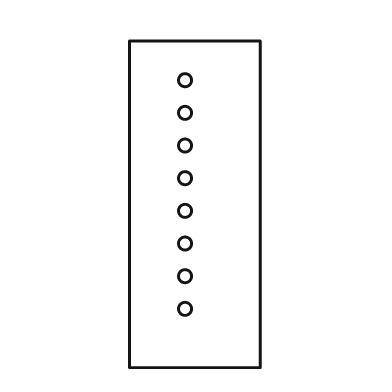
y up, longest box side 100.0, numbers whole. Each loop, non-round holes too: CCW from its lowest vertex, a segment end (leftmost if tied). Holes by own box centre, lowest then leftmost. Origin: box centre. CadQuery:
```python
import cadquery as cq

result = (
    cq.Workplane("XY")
    .moveTo(-20.0, -50.0)
    .lineTo(20.0, -50.0)
    .lineTo(20.0, 50.0)
    .lineTo(-20.0, 50.0)
    .close()
    .moveTo(-3.0, -32.0)
    .circle(2.0)
    .moveTo(-3.0, -22.0)
    .circle(2.0)
    .moveTo(-3.0, -12.0)
    .circle(2.0)
    .moveTo(-3.0, -2.0)
    .circle(2.0)
    .moveTo(-3.0, 8.0)
    .circle(2.0)
    .moveTo(-3.0, 18.0)
    .circle(2.0)
    .moveTo(-3.0, 28.0)
    .circle(2.0)
    .moveTo(-3.0, 38.0)
    .circle(2.0)
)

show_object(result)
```